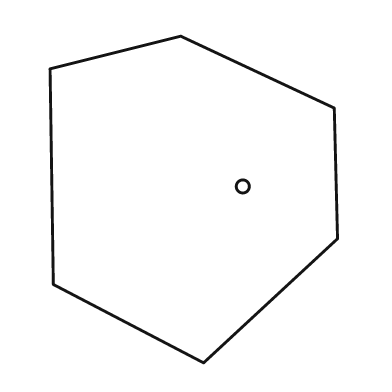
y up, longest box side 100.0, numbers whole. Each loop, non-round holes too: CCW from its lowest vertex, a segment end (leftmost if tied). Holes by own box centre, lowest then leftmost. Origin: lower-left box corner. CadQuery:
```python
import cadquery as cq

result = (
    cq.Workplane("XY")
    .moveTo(47.0, 0.0)
    .lineTo(88.0, 38.0)
    .lineTo(87.0, 78.0)
    .lineTo(40.0, 100.0)
    .lineTo(0.0, 90.0)
    .lineTo(1.0, 24.0)
    .close()
    .moveTo(59.0, 54.0)
    .circle(2.0)
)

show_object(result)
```